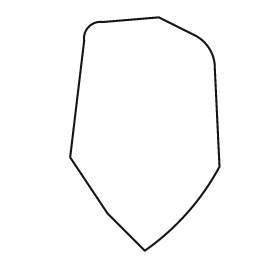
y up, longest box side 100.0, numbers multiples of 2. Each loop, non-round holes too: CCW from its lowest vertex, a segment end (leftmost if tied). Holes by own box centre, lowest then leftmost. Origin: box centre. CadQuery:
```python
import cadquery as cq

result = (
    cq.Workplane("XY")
    .moveTo(0.0, -50.0)
    .threePointArc((18.0, -34.0), (32.0, -14.0))
    .lineTo(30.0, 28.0)
    .threePointArc((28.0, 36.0), (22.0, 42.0))
    .lineTo(6.0, 50.0)
    .lineTo(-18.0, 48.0)
    .threePointArc((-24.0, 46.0), (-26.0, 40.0))
    .lineTo(-32.0, -10.0)
    .lineTo(-16.0, -34.0)
    .close()
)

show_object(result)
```